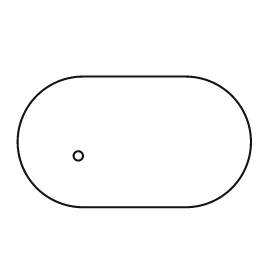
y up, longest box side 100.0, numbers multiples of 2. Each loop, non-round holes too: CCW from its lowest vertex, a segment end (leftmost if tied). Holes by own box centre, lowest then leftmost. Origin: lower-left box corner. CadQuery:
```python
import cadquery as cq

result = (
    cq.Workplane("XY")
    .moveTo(28.0, 0.0)
    .lineTo(72.0, 0.0)
    .threePointArc((100.0, 28.0), (72.0, 56.0))
    .lineTo(28.0, 56.0)
    .threePointArc((0.0, 28.0), (28.0, 0.0))
    .close()
    .moveTo(26.0, 22.0)
    .circle(2.0)
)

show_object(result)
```